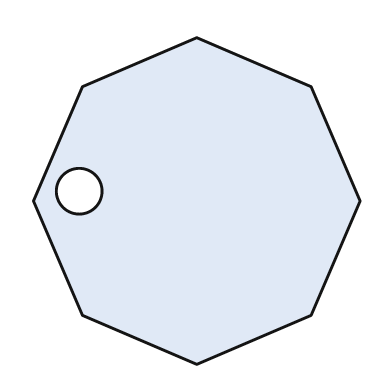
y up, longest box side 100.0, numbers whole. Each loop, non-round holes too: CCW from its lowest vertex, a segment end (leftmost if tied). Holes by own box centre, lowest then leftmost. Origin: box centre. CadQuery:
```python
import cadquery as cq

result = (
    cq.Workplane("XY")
    .moveTo(0.0, -50.0)
    .lineTo(35.0, -35.0)
    .lineTo(50.0, 0.0)
    .lineTo(35.0, 35.0)
    .lineTo(0.0, 50.0)
    .lineTo(-35.0, 35.0)
    .lineTo(-50.0, 0.0)
    .lineTo(-35.0, -35.0)
    .close()
    .moveTo(-36.0, 3.0)
    .circle(7.0)
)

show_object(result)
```